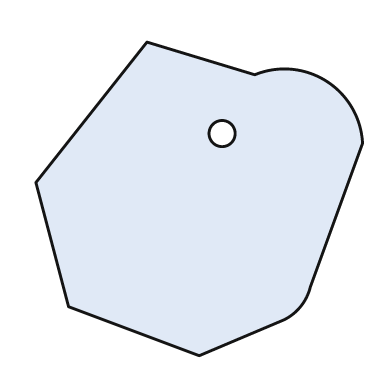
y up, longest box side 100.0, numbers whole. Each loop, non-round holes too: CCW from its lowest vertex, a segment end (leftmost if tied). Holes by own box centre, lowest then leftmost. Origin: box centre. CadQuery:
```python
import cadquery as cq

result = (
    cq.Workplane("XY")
    .moveTo(0.0, -48.0)
    .lineTo(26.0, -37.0)
    .threePointArc((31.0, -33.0), (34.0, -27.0))
    .lineTo(50.0, 17.0)
    .threePointArc((39.0, 36.0), (17.0, 38.0))
    .lineTo(-16.0, 48.0)
    .lineTo(-50.0, 5.0)
    .lineTo(-40.0, -33.0)
    .close()
    .moveTo(7.0, 20.0)
    .circle(4.0)
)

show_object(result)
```